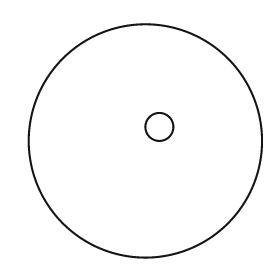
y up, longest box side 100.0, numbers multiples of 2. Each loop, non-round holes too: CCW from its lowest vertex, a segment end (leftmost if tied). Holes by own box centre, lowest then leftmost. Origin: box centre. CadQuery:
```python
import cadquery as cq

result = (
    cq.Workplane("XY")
    .moveTo(0.0, 0.0)
    .circle(50.0)
    .moveTo(6.0, 6.0)
    .circle(6.0)
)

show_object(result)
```